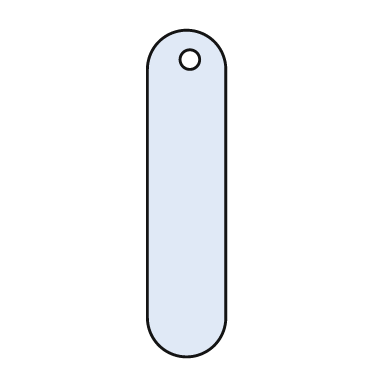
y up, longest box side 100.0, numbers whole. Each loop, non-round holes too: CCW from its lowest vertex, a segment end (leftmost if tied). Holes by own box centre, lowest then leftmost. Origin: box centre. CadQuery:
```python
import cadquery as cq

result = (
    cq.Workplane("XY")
    .moveTo(-12.0, -38.0)
    .threePointArc((0.0, -50.0), (12.0, -38.0))
    .lineTo(12.0, 38.0)
    .threePointArc((0.0, 50.0), (-12.0, 38.0))
    .close()
    .moveTo(1.0, 41.0)
    .circle(3.0)
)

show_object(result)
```